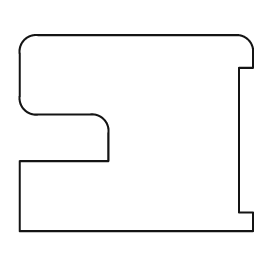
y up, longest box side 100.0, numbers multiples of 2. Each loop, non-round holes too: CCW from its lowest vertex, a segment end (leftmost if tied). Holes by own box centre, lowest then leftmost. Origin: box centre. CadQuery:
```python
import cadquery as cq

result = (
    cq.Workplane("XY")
    .moveTo(-50.0, -42.0)
    .lineTo(50.0, -42.0)
    .lineTo(50.0, -34.0)
    .lineTo(44.0, -34.0)
    .lineTo(44.0, 28.0)
    .lineTo(50.0, 28.0)
    .lineTo(50.0, 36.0)
    .threePointArc((48.0, 40.0), (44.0, 42.0))
    .lineTo(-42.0, 42.0)
    .threePointArc((-48.0, 40.0), (-50.0, 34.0))
    .lineTo(-50.0, 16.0)
    .threePointArc((-48.0, 10.0), (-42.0, 8.0))
    .lineTo(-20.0, 8.0)
    .threePointArc((-14.0, 6.0), (-12.0, 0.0))
    .lineTo(-12.0, -12.0)
    .lineTo(-50.0, -12.0)
    .close()
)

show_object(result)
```